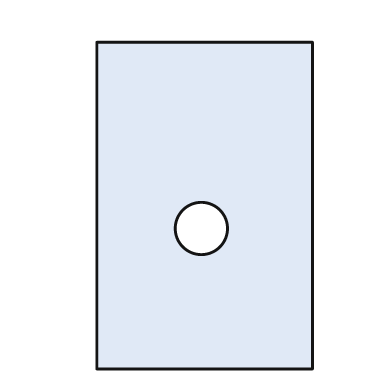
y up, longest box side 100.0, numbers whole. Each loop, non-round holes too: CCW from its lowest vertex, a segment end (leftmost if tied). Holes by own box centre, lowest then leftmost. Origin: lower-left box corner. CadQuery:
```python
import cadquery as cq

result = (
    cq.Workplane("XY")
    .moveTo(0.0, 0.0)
    .lineTo(66.0, 0.0)
    .lineTo(66.0, 100.0)
    .lineTo(0.0, 100.0)
    .close()
    .moveTo(32.0, 43.0)
    .circle(8.0)
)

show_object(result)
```